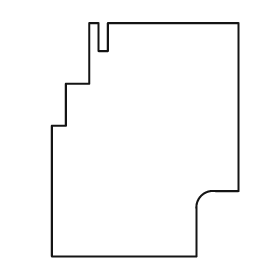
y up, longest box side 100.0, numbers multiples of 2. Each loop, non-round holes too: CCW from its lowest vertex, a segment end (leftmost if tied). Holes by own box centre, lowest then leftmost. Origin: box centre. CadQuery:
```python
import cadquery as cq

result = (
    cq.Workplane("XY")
    .moveTo(-40.0, -50.0)
    .lineTo(22.0, -50.0)
    .lineTo(22.0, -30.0)
    .threePointArc((24.0, -24.0), (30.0, -22.0))
    .lineTo(40.0, -22.0)
    .lineTo(40.0, 50.0)
    .lineTo(-16.0, 50.0)
    .lineTo(-16.0, 38.0)
    .lineTo(-20.0, 38.0)
    .lineTo(-20.0, 50.0)
    .lineTo(-24.0, 50.0)
    .lineTo(-24.0, 24.0)
    .lineTo(-34.0, 24.0)
    .lineTo(-34.0, 6.0)
    .lineTo(-40.0, 6.0)
    .close()
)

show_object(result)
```